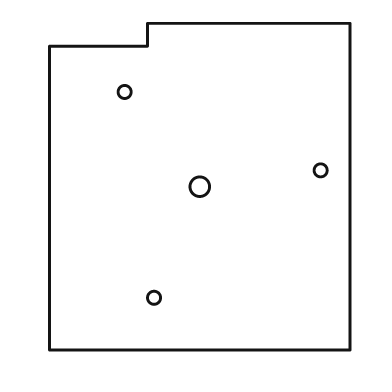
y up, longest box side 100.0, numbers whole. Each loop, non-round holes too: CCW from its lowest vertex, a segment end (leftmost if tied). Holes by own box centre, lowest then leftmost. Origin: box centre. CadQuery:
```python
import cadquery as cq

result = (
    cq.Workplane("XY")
    .moveTo(-46.0, -50.0)
    .lineTo(46.0, -50.0)
    .lineTo(46.0, 50.0)
    .lineTo(-16.0, 50.0)
    .lineTo(-16.0, 43.0)
    .lineTo(-46.0, 43.0)
    .close()
    .moveTo(-14.0, -34.0)
    .circle(2.0)
    .moveTo(0.0, 0.0)
    .circle(3.0)
    .moveTo(37.0, 5.0)
    .circle(2.0)
    .moveTo(-23.0, 29.0)
    .circle(2.0)
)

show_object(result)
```